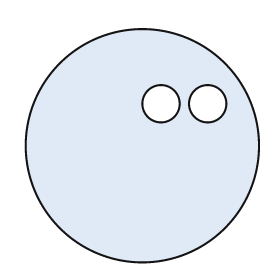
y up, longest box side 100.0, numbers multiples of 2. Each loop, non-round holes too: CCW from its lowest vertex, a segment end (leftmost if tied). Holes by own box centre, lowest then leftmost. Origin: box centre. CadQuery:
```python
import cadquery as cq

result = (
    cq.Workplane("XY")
    .moveTo(0.0, 0.0)
    .circle(50.0)
    .moveTo(8.0, 18.0)
    .circle(8.0)
    .moveTo(28.0, 18.0)
    .circle(8.0)
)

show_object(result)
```